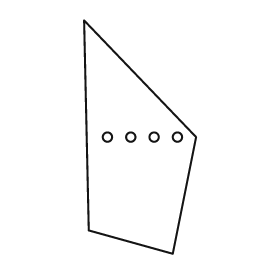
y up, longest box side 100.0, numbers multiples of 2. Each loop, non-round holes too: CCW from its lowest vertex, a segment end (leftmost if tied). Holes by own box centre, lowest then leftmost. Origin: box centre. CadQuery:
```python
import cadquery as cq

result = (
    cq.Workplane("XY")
    .moveTo(14.0, -50.0)
    .lineTo(24.0, 0.0)
    .lineTo(-24.0, 50.0)
    .lineTo(-22.0, -40.0)
    .close()
    .moveTo(-14.0, 0.0)
    .circle(2.0)
    .moveTo(-4.0, 0.0)
    .circle(2.0)
    .moveTo(6.0, 0.0)
    .circle(2.0)
    .moveTo(16.0, 0.0)
    .circle(2.0)
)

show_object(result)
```